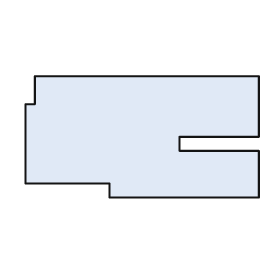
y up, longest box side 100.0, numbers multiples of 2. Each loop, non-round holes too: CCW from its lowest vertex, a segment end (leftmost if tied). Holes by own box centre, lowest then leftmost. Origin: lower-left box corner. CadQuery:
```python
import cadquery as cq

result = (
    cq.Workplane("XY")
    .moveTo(36.0, 0.0)
    .lineTo(100.0, 0.0)
    .lineTo(100.0, 20.0)
    .lineTo(66.0, 20.0)
    .lineTo(66.0, 26.0)
    .lineTo(100.0, 26.0)
    .lineTo(100.0, 52.0)
    .lineTo(4.0, 52.0)
    .lineTo(4.0, 40.0)
    .lineTo(0.0, 40.0)
    .lineTo(0.0, 6.0)
    .lineTo(36.0, 6.0)
    .close()
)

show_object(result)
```